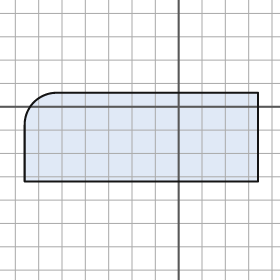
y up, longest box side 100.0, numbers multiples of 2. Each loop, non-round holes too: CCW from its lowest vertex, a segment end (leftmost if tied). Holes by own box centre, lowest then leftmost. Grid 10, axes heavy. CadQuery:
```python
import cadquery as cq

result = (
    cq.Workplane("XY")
    .moveTo(-66.0, -32.0)
    .lineTo(34.0, -32.0)
    .lineTo(34.0, 6.0)
    .lineTo(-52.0, 6.0)
    .threePointArc((-62.0, 2.0), (-66.0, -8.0))
    .close()
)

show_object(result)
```